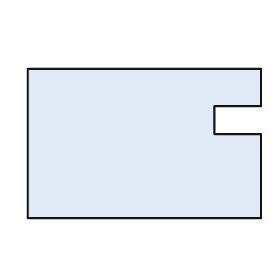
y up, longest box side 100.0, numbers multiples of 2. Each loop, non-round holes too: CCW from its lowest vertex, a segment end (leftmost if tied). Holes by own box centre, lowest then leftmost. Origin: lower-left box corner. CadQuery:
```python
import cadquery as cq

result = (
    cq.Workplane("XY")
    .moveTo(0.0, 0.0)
    .lineTo(100.0, 0.0)
    .lineTo(100.0, 36.0)
    .lineTo(80.0, 36.0)
    .lineTo(80.0, 48.0)
    .lineTo(100.0, 48.0)
    .lineTo(100.0, 64.0)
    .lineTo(0.0, 64.0)
    .close()
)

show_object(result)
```